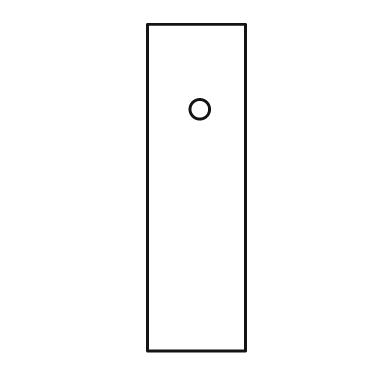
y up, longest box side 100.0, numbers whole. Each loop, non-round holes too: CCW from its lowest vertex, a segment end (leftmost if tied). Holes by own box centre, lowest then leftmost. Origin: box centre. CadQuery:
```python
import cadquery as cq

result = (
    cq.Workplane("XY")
    .moveTo(-15.0, -50.0)
    .lineTo(15.0, -50.0)
    .lineTo(15.0, 50.0)
    .lineTo(-15.0, 50.0)
    .close()
    .moveTo(1.0, 24.0)
    .circle(3.0)
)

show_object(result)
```